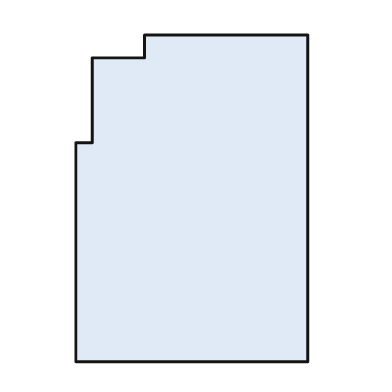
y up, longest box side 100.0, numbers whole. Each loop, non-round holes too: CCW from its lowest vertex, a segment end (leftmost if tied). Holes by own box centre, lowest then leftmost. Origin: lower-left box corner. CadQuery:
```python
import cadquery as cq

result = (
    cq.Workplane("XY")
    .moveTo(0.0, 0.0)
    .lineTo(71.0, 0.0)
    .lineTo(71.0, 100.0)
    .lineTo(21.0, 100.0)
    .lineTo(21.0, 93.0)
    .lineTo(5.0, 93.0)
    .lineTo(5.0, 67.0)
    .lineTo(0.0, 67.0)
    .close()
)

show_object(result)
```